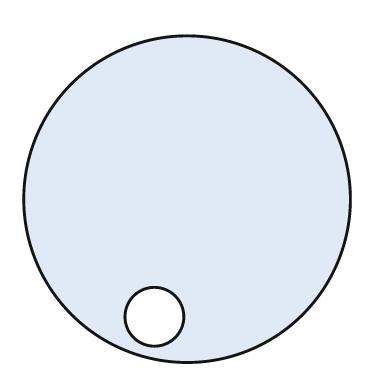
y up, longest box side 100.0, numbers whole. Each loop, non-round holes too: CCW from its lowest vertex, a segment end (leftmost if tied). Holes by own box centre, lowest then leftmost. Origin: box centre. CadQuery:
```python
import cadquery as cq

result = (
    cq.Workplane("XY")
    .moveTo(0.0, 0.0)
    .circle(50.0)
    .moveTo(-10.0, -36.0)
    .circle(9.0)
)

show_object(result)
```